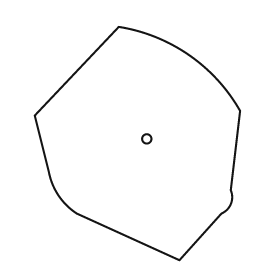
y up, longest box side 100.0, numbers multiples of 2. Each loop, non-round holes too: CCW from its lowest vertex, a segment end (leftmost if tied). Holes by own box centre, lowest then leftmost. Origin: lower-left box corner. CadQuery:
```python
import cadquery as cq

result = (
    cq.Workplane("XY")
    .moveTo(62.0, 0.0)
    .lineTo(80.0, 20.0)
    .threePointArc((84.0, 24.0), (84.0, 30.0))
    .lineTo(88.0, 64.0)
    .threePointArc((66.0, 88.0), (36.0, 100.0))
    .lineTo(0.0, 62.0)
    .lineTo(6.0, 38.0)
    .threePointArc((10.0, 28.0), (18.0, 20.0))
    .close()
    .moveTo(48.0, 52.0)
    .circle(2.0)
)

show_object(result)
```